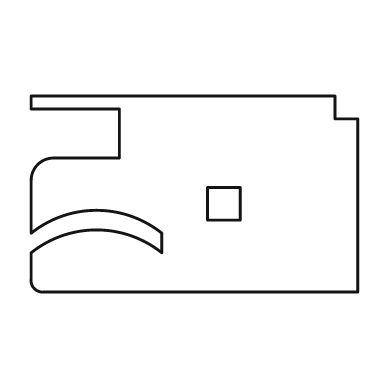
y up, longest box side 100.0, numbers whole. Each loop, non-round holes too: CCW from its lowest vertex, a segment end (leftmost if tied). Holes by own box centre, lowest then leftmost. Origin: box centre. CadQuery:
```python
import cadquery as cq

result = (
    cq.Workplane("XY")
    .moveTo(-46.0, -30.0)
    .lineTo(50.0, -30.0)
    .lineTo(50.0, 23.0)
    .lineTo(43.0, 23.0)
    .lineTo(43.0, 30.0)
    .lineTo(-50.0, 30.0)
    .lineTo(-50.0, 26.0)
    .lineTo(-23.0, 26.0)
    .lineTo(-23.0, 11.0)
    .lineTo(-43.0, 11.0)
    .threePointArc((-48.0, 9.0), (-50.0, 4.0))
    .lineTo(-50.0, -12.0)
    .threePointArc((-30.0, -5.0), (-10.0, -12.0))
    .lineTo(-10.0, -18.0)
    .threePointArc((-30.0, -11.0), (-50.0, -18.0))
    .lineTo(-50.0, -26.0)
    .threePointArc((-49.0, -29.0), (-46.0, -30.0))
    .close()
    .moveTo(4.0, -8.0)
    .lineTo(14.0, -8.0)
    .lineTo(14.0, 2.0)
    .lineTo(4.0, 2.0)
    .close()
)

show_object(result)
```